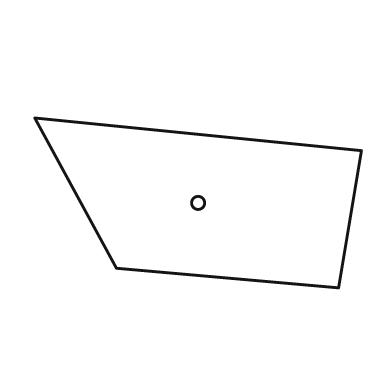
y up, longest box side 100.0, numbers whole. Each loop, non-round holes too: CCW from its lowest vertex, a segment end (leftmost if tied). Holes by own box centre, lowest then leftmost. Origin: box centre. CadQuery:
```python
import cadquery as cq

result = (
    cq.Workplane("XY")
    .moveTo(43.0, -26.0)
    .lineTo(50.0, 16.0)
    .lineTo(-50.0, 26.0)
    .lineTo(-25.0, -20.0)
    .close()
    .moveTo(0.0, 0.0)
    .circle(2.0)
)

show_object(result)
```